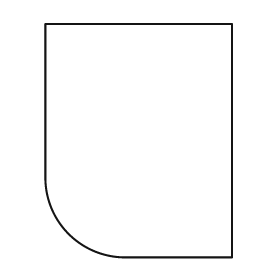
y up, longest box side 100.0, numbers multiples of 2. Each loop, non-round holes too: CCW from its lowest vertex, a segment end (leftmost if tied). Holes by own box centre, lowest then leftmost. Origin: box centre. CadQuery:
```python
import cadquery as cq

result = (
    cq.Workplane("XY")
    .moveTo(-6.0, -50.0)
    .lineTo(40.0, -50.0)
    .lineTo(40.0, 50.0)
    .lineTo(-40.0, 50.0)
    .lineTo(-40.0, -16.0)
    .threePointArc((-30.0, -40.0), (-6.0, -50.0))
    .close()
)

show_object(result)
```